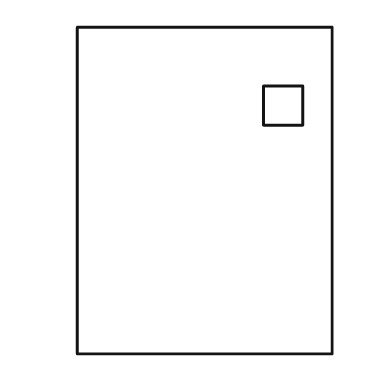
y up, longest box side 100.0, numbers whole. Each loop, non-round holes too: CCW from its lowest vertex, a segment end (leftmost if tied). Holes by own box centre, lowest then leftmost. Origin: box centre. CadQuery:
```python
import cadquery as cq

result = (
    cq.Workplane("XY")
    .moveTo(-39.0, -50.0)
    .lineTo(39.0, -50.0)
    .lineTo(39.0, 50.0)
    .lineTo(-39.0, 50.0)
    .close()
    .moveTo(18.0, 20.0)
    .lineTo(30.0, 20.0)
    .lineTo(30.0, 32.0)
    .lineTo(18.0, 32.0)
    .close()
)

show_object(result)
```